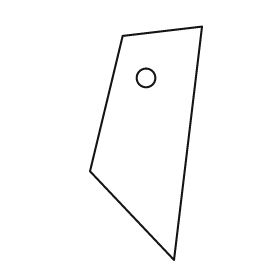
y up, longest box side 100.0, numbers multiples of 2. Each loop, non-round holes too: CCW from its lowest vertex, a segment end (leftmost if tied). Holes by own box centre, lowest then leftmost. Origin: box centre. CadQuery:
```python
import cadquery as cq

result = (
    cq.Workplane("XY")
    .moveTo(12.0, -50.0)
    .lineTo(24.0, 50.0)
    .lineTo(-10.0, 46.0)
    .lineTo(-24.0, -12.0)
    .close()
    .moveTo(0.0, 28.0)
    .circle(4.0)
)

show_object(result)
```